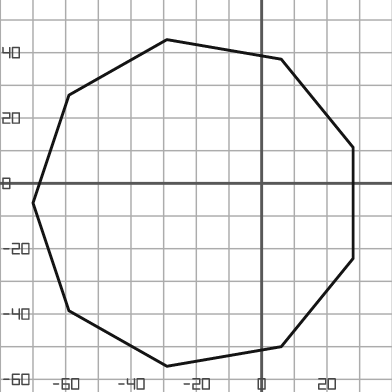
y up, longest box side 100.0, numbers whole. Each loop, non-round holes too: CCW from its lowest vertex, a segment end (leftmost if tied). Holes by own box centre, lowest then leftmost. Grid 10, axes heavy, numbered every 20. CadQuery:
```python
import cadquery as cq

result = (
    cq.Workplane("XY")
    .moveTo(-29.0, -56.0)
    .lineTo(6.0, -50.0)
    .lineTo(28.0, -23.0)
    .lineTo(28.0, 11.0)
    .lineTo(6.0, 38.0)
    .lineTo(-29.0, 44.0)
    .lineTo(-59.0, 27.0)
    .lineTo(-70.0, -6.0)
    .lineTo(-59.0, -39.0)
    .close()
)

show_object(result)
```